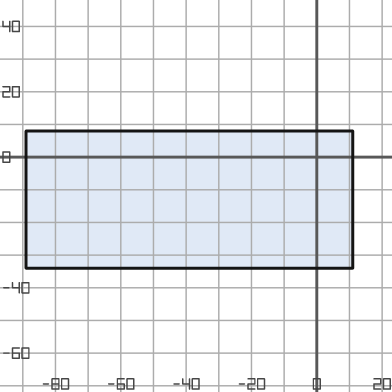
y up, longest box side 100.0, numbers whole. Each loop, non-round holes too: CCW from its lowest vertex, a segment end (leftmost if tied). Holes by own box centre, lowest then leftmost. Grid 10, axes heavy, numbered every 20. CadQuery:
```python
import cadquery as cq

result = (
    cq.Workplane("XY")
    .moveTo(-89.0, -34.0)
    .lineTo(11.0, -34.0)
    .lineTo(11.0, 8.0)
    .lineTo(-89.0, 8.0)
    .close()
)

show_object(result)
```